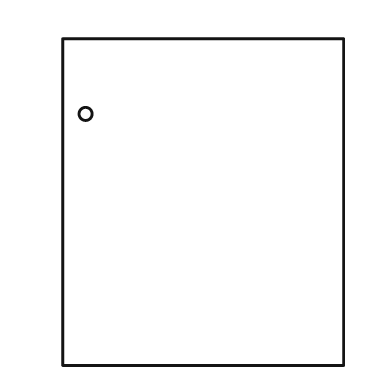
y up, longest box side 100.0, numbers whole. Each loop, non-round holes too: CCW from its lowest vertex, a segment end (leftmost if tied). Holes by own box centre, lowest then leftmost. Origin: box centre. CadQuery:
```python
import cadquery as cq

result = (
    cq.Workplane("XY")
    .moveTo(-43.0, -50.0)
    .lineTo(43.0, -50.0)
    .lineTo(43.0, 50.0)
    .lineTo(-43.0, 50.0)
    .close()
    .moveTo(-36.0, 27.0)
    .circle(2.0)
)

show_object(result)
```